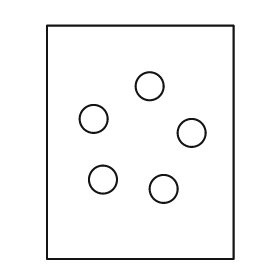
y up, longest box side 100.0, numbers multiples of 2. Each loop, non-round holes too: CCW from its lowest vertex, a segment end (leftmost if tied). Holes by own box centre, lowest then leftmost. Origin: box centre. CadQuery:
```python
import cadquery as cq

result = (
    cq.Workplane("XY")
    .moveTo(-40.0, -50.0)
    .lineTo(40.0, -50.0)
    .lineTo(40.0, 50.0)
    .lineTo(-40.0, 50.0)
    .close()
    .moveTo(10.0, -20.0)
    .circle(6.0)
    .moveTo(-16.0, -16.0)
    .circle(6.0)
    .moveTo(22.0, 4.0)
    .circle(6.0)
    .moveTo(-20.0, 10.0)
    .circle(6.0)
    .moveTo(4.0, 24.0)
    .circle(6.0)
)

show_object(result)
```